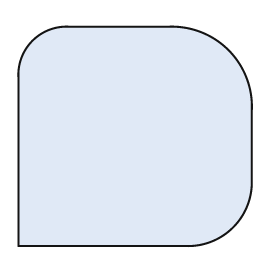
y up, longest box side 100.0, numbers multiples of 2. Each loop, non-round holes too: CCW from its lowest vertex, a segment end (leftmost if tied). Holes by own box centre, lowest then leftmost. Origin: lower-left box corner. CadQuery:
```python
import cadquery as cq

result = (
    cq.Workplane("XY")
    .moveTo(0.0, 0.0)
    .lineTo(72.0, 0.0)
    .threePointArc((92.0, 8.0), (100.0, 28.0))
    .lineTo(100.0, 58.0)
    .threePointArc((90.0, 84.0), (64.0, 94.0))
    .lineTo(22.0, 94.0)
    .threePointArc((6.0, 88.0), (0.0, 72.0))
    .close()
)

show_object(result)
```